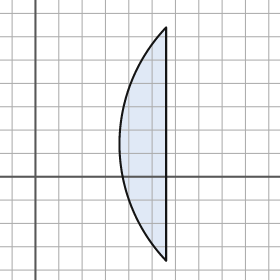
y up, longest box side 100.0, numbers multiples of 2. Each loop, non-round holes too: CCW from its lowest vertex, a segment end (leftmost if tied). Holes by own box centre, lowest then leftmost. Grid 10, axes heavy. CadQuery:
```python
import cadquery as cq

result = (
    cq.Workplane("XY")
    .moveTo(56.0, -36.0)
    .lineTo(56.0, 64.0)
    .threePointArc((36.0, 14.0), (56.0, -36.0))
    .close()
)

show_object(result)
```